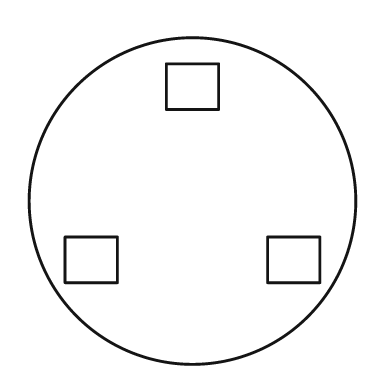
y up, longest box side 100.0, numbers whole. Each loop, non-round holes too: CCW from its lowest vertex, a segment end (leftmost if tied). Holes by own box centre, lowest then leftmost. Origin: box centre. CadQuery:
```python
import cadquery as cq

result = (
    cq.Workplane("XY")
    .moveTo(0.0, 0.0)
    .circle(50.0)
    .moveTo(-39.0, -25.0)
    .lineTo(-23.0, -25.0)
    .lineTo(-23.0, -11.0)
    .lineTo(-39.0, -11.0)
    .close()
    .moveTo(23.0, -25.0)
    .lineTo(39.0, -25.0)
    .lineTo(39.0, -11.0)
    .lineTo(23.0, -11.0)
    .close()
    .moveTo(-8.0, 28.0)
    .lineTo(8.0, 28.0)
    .lineTo(8.0, 42.0)
    .lineTo(-8.0, 42.0)
    .close()
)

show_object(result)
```